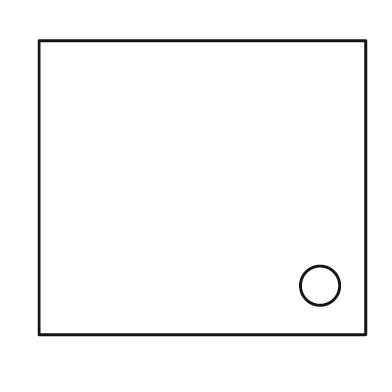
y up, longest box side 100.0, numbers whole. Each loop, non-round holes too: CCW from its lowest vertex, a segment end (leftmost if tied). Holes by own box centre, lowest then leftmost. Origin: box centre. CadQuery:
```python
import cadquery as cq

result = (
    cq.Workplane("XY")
    .moveTo(-50.0, -45.0)
    .lineTo(50.0, -45.0)
    .lineTo(50.0, 45.0)
    .lineTo(-50.0, 45.0)
    .close()
    .moveTo(36.0, -30.0)
    .circle(6.0)
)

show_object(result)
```